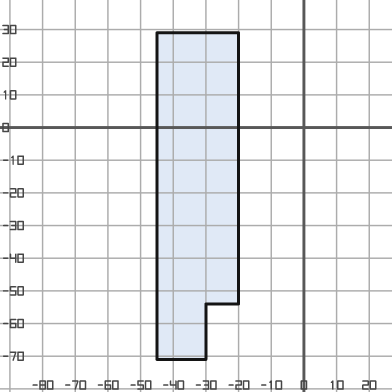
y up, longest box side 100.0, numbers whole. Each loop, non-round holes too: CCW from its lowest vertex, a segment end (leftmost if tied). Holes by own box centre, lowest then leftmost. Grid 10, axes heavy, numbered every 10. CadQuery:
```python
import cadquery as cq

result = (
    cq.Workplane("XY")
    .moveTo(-45.0, -71.0)
    .lineTo(-30.0, -71.0)
    .lineTo(-30.0, -54.0)
    .lineTo(-20.0, -54.0)
    .lineTo(-20.0, 29.0)
    .lineTo(-45.0, 29.0)
    .close()
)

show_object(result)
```